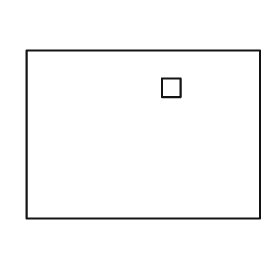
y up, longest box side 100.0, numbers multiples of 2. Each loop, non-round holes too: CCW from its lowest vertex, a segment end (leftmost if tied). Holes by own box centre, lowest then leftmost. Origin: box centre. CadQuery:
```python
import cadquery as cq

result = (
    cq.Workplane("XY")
    .moveTo(-50.0, -36.0)
    .lineTo(50.0, -36.0)
    .lineTo(50.0, 36.0)
    .lineTo(-50.0, 36.0)
    .close()
    .moveTo(8.0, 16.0)
    .lineTo(16.0, 16.0)
    .lineTo(16.0, 24.0)
    .lineTo(8.0, 24.0)
    .close()
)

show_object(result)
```